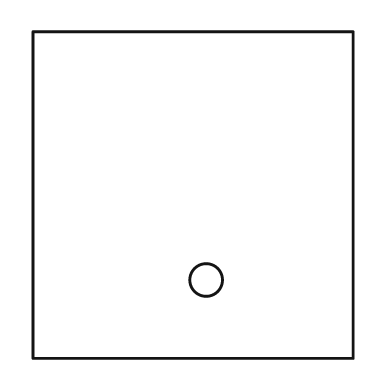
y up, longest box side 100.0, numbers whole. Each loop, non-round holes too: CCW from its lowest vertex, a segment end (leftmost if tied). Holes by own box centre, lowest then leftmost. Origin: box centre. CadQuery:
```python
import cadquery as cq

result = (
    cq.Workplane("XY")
    .moveTo(-49.0, -50.0)
    .lineTo(49.0, -50.0)
    .lineTo(49.0, 50.0)
    .lineTo(-49.0, 50.0)
    .close()
    .moveTo(4.0, -26.0)
    .circle(5.0)
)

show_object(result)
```